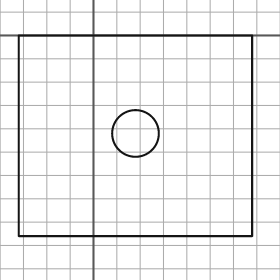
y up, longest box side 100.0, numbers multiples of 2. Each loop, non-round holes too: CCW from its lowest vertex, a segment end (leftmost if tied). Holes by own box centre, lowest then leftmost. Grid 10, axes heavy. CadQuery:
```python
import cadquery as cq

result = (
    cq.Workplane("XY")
    .moveTo(-32.0, -86.0)
    .lineTo(68.0, -86.0)
    .lineTo(68.0, 0.0)
    .lineTo(-32.0, 0.0)
    .close()
    .moveTo(18.0, -42.0)
    .circle(10.0)
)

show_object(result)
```